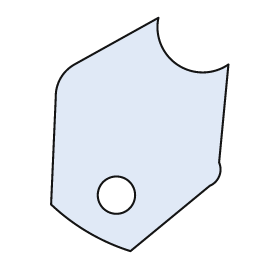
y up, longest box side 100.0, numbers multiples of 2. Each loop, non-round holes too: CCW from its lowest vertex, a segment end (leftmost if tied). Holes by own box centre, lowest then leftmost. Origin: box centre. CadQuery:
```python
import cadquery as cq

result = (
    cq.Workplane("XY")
    .moveTo(-4.0, -50.0)
    .lineTo(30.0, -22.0)
    .threePointArc((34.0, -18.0), (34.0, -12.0))
    .lineTo(38.0, 30.0)
    .threePointArc((16.0, 30.0), (8.0, 50.0))
    .lineTo(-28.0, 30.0)
    .threePointArc((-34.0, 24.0), (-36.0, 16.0))
    .lineTo(-38.0, -30.0)
    .threePointArc((-22.0, -42.0), (-4.0, -50.0))
    .close()
    .moveTo(-10.0, -26.0)
    .circle(8.0)
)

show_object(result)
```